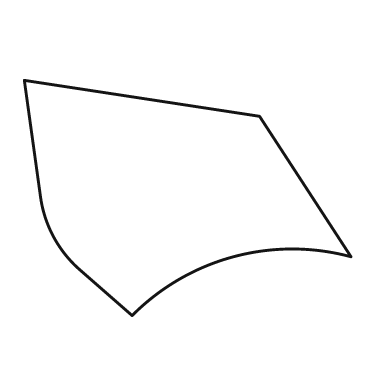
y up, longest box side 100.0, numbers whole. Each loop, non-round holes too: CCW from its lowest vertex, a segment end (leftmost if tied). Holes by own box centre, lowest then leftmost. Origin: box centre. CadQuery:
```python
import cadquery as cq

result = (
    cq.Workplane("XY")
    .moveTo(-17.0, -36.0)
    .threePointArc((14.0, -18.0), (50.0, -18.0))
    .lineTo(22.0, 25.0)
    .lineTo(-50.0, 36.0)
    .lineTo(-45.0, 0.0)
    .threePointArc((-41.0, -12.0), (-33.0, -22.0))
    .close()
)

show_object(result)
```